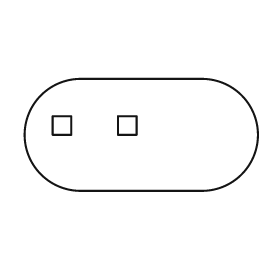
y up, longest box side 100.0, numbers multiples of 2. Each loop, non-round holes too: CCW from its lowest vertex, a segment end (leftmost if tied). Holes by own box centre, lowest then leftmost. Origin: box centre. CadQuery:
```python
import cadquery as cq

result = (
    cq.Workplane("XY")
    .moveTo(-26.0, -24.0)
    .lineTo(26.0, -24.0)
    .threePointArc((50.0, 0.0), (26.0, 24.0))
    .lineTo(-26.0, 24.0)
    .threePointArc((-50.0, 0.0), (-26.0, -24.0))
    .close()
    .moveTo(-38.0, 0.0)
    .lineTo(-30.0, 0.0)
    .lineTo(-30.0, 8.0)
    .lineTo(-38.0, 8.0)
    .close()
    .moveTo(-10.0, 0.0)
    .lineTo(-2.0, 0.0)
    .lineTo(-2.0, 8.0)
    .lineTo(-10.0, 8.0)
    .close()
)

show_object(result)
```